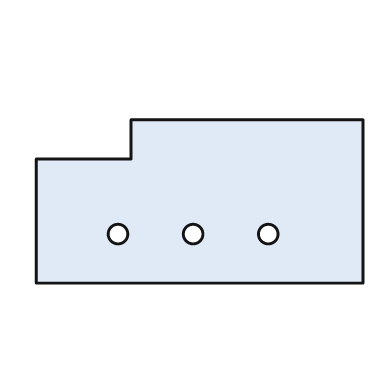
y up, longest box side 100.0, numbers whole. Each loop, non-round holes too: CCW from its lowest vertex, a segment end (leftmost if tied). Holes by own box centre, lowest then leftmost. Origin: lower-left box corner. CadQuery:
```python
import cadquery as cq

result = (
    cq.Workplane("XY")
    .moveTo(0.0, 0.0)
    .lineTo(100.0, 0.0)
    .lineTo(100.0, 50.0)
    .lineTo(29.0, 50.0)
    .lineTo(29.0, 38.0)
    .lineTo(0.0, 38.0)
    .close()
    .moveTo(25.0, 15.0)
    .circle(3.0)
    .moveTo(48.0, 15.0)
    .circle(3.0)
    .moveTo(71.0, 15.0)
    .circle(3.0)
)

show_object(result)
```